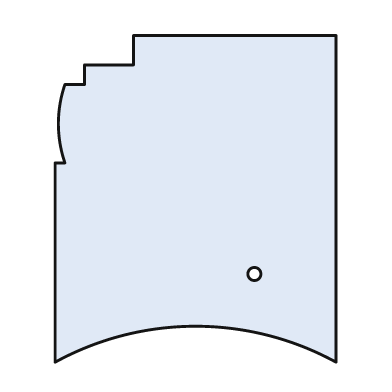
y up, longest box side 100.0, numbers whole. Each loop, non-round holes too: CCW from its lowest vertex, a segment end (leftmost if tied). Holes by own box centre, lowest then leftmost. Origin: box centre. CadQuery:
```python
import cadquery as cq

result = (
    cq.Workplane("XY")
    .moveTo(-43.0, -50.0)
    .threePointArc((0.0, -39.0), (43.0, -50.0))
    .lineTo(43.0, 50.0)
    .lineTo(-19.0, 50.0)
    .lineTo(-19.0, 41.0)
    .lineTo(-34.0, 41.0)
    .lineTo(-34.0, 35.0)
    .lineTo(-40.0, 35.0)
    .threePointArc((-42.0, 23.0), (-40.0, 11.0))
    .lineTo(-43.0, 11.0)
    .close()
    .moveTo(18.0, -23.0)
    .circle(2.0)
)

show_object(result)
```